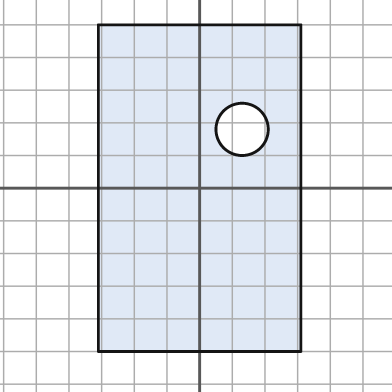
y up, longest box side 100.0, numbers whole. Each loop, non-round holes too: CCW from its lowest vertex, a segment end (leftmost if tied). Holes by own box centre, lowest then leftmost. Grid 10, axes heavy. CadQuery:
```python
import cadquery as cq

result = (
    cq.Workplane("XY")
    .moveTo(-31.0, -50.0)
    .lineTo(31.0, -50.0)
    .lineTo(31.0, 50.0)
    .lineTo(-31.0, 50.0)
    .close()
    .moveTo(13.0, 18.0)
    .circle(8.0)
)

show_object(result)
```